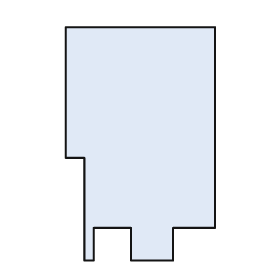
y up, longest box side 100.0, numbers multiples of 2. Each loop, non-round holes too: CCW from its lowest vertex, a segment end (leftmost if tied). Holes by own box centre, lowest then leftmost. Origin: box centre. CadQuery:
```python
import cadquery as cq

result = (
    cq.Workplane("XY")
    .moveTo(-24.0, -50.0)
    .lineTo(-20.0, -50.0)
    .lineTo(-20.0, -36.0)
    .lineTo(-4.0, -36.0)
    .lineTo(-4.0, -50.0)
    .lineTo(14.0, -50.0)
    .lineTo(14.0, -36.0)
    .lineTo(32.0, -36.0)
    .lineTo(32.0, 50.0)
    .lineTo(-32.0, 50.0)
    .lineTo(-32.0, -6.0)
    .lineTo(-24.0, -6.0)
    .close()
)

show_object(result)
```